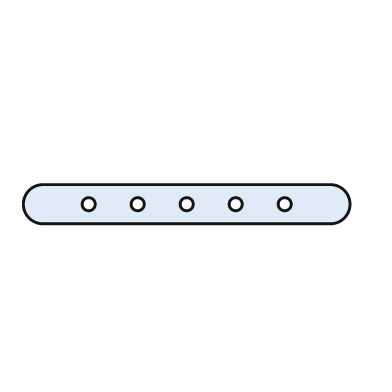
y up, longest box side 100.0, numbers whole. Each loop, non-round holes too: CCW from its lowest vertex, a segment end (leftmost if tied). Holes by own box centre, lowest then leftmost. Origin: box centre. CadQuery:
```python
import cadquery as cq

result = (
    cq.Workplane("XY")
    .moveTo(-44.0, -6.0)
    .lineTo(44.0, -6.0)
    .threePointArc((50.0, 0.0), (44.0, 6.0))
    .lineTo(-44.0, 6.0)
    .threePointArc((-50.0, 0.0), (-44.0, -6.0))
    .close()
    .moveTo(-30.0, 0.0)
    .circle(2.0)
    .moveTo(-15.0, 0.0)
    .circle(2.0)
    .moveTo(0.0, 0.0)
    .circle(2.0)
    .moveTo(15.0, 0.0)
    .circle(2.0)
    .moveTo(30.0, 0.0)
    .circle(2.0)
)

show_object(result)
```